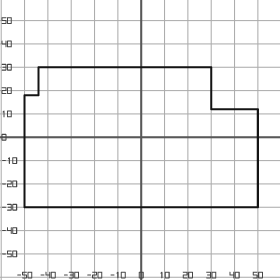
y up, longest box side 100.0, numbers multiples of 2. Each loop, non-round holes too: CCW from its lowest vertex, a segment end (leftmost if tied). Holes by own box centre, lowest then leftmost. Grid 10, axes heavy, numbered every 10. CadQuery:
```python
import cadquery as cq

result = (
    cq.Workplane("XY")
    .moveTo(-50.0, -30.0)
    .lineTo(50.0, -30.0)
    .lineTo(50.0, 12.0)
    .lineTo(30.0, 12.0)
    .lineTo(30.0, 30.0)
    .lineTo(-44.0, 30.0)
    .lineTo(-44.0, 18.0)
    .lineTo(-50.0, 18.0)
    .close()
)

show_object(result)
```